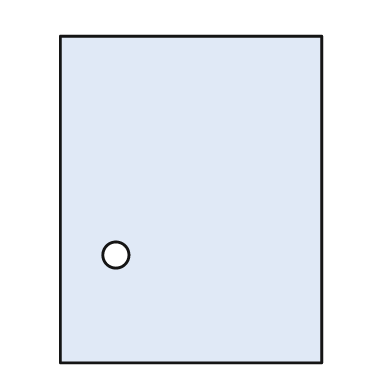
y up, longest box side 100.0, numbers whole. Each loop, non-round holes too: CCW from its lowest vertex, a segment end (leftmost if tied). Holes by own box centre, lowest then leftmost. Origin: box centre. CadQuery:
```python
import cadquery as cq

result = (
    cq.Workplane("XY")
    .moveTo(-40.0, -50.0)
    .lineTo(40.0, -50.0)
    .lineTo(40.0, 50.0)
    .lineTo(-40.0, 50.0)
    .close()
    .moveTo(-23.0, -17.0)
    .circle(4.0)
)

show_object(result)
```